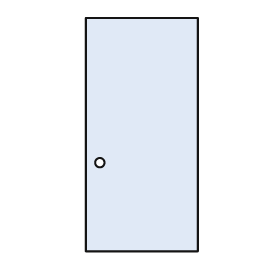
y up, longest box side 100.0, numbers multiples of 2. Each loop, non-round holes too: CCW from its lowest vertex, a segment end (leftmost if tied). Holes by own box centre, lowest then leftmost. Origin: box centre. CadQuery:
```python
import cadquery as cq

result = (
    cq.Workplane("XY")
    .moveTo(-24.0, -50.0)
    .lineTo(24.0, -50.0)
    .lineTo(24.0, 50.0)
    .lineTo(-24.0, 50.0)
    .close()
    .moveTo(-18.0, -12.0)
    .circle(2.0)
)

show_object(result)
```